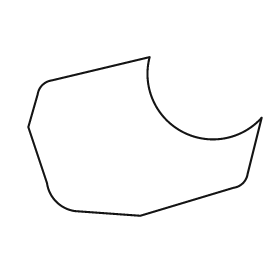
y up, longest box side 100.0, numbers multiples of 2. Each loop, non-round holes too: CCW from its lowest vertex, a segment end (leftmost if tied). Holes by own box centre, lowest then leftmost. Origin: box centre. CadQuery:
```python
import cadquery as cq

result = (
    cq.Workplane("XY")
    .moveTo(-2.0, -34.0)
    .lineTo(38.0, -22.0)
    .threePointArc((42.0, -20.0), (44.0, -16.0))
    .lineTo(50.0, 8.0)
    .threePointArc((16.0, 2.0), (2.0, 34.0))
    .lineTo(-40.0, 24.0)
    .threePointArc((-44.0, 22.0), (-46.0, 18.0))
    .lineTo(-50.0, 4.0)
    .lineTo(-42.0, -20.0)
    .threePointArc((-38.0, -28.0), (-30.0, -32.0))
    .close()
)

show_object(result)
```